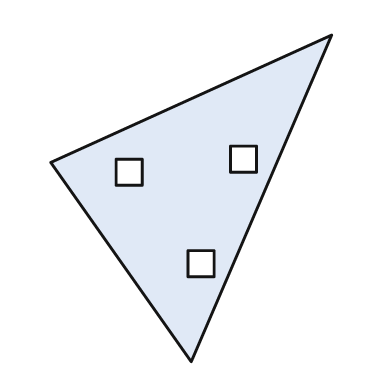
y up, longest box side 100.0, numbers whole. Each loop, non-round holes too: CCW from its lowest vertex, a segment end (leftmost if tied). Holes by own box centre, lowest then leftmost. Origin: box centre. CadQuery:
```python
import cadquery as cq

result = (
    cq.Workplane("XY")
    .moveTo(0.0, -50.0)
    .lineTo(43.0, 50.0)
    .lineTo(-43.0, 11.0)
    .close()
    .moveTo(-1.0, -24.0)
    .lineTo(7.0, -24.0)
    .lineTo(7.0, -16.0)
    .lineTo(-1.0, -16.0)
    .close()
    .moveTo(-23.0, 4.0)
    .lineTo(-15.0, 4.0)
    .lineTo(-15.0, 12.0)
    .lineTo(-23.0, 12.0)
    .close()
    .moveTo(12.0, 8.0)
    .lineTo(20.0, 8.0)
    .lineTo(20.0, 16.0)
    .lineTo(12.0, 16.0)
    .close()
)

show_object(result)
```